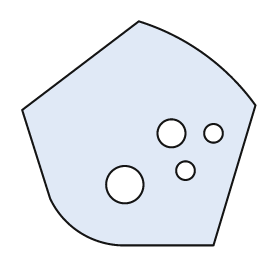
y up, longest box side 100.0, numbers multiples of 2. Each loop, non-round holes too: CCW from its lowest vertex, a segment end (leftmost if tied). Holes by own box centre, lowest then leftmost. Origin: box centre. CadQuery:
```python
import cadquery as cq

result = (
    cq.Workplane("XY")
    .moveTo(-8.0, -48.0)
    .lineTo(32.0, -48.0)
    .lineTo(50.0, 12.0)
    .threePointArc((28.0, 34.0), (0.0, 48.0))
    .lineTo(-50.0, 10.0)
    .lineTo(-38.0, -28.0)
    .threePointArc((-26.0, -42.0), (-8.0, -48.0))
    .close()
    .moveTo(-6.0, -22.0)
    .circle(8.0)
    .moveTo(20.0, -16.0)
    .circle(4.0)
    .moveTo(14.0, 0.0)
    .circle(6.0)
    .moveTo(32.0, 0.0)
    .circle(4.0)
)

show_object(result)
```